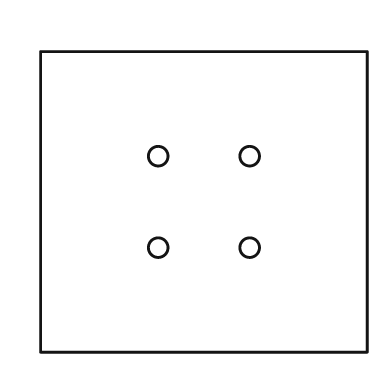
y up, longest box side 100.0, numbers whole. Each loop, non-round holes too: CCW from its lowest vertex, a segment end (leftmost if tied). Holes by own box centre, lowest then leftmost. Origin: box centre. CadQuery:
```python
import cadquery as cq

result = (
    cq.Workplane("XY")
    .moveTo(-50.0, -46.0)
    .lineTo(50.0, -46.0)
    .lineTo(50.0, 46.0)
    .lineTo(-50.0, 46.0)
    .close()
    .moveTo(-14.0, -14.0)
    .circle(3.0)
    .moveTo(14.0, -14.0)
    .circle(3.0)
    .moveTo(-14.0, 14.0)
    .circle(3.0)
    .moveTo(14.0, 14.0)
    .circle(3.0)
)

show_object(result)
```